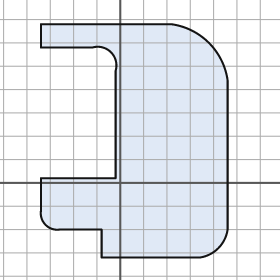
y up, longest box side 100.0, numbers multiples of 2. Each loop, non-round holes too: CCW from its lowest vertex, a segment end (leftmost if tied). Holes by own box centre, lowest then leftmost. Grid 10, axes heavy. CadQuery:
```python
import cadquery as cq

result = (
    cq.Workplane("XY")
    .moveTo(-8.0, -32.0)
    .lineTo(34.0, -32.0)
    .threePointArc((42.0, -28.0), (46.0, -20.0))
    .lineTo(46.0, 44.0)
    .threePointArc((38.0, 60.0), (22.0, 68.0))
    .lineTo(-34.0, 68.0)
    .lineTo(-34.0, 58.0)
    .lineTo(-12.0, 58.0)
    .threePointArc((-4.0, 56.0), (-2.0, 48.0))
    .lineTo(-2.0, 2.0)
    .lineTo(-34.0, 2.0)
    .lineTo(-34.0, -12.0)
    .threePointArc((-32.0, -18.0), (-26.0, -20.0))
    .lineTo(-8.0, -20.0)
    .close()
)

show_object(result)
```